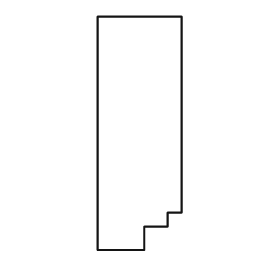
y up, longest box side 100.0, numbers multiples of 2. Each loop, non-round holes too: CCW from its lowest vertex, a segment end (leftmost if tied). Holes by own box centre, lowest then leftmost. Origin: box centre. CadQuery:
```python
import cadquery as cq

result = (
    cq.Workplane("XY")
    .moveTo(-18.0, -50.0)
    .lineTo(2.0, -50.0)
    .lineTo(2.0, -40.0)
    .lineTo(12.0, -40.0)
    .lineTo(12.0, -34.0)
    .lineTo(18.0, -34.0)
    .lineTo(18.0, 50.0)
    .lineTo(-18.0, 50.0)
    .close()
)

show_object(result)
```